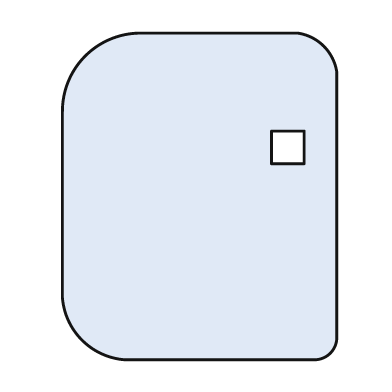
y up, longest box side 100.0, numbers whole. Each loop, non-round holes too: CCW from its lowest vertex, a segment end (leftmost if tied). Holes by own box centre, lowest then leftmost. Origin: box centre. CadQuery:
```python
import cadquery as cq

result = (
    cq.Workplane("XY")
    .moveTo(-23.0, -50.0)
    .lineTo(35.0, -50.0)
    .threePointArc((40.0, -48.0), (42.0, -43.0))
    .lineTo(42.0, 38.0)
    .threePointArc((38.0, 46.0), (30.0, 50.0))
    .lineTo(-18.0, 50.0)
    .threePointArc((-35.0, 43.0), (-42.0, 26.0))
    .lineTo(-42.0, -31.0)
    .threePointArc((-36.0, -44.0), (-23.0, -50.0))
    .close()
    .moveTo(22.0, 10.0)
    .lineTo(32.0, 10.0)
    .lineTo(32.0, 20.0)
    .lineTo(22.0, 20.0)
    .close()
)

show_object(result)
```